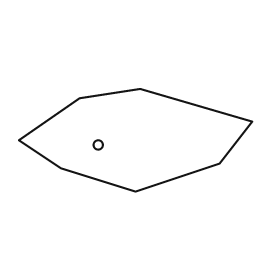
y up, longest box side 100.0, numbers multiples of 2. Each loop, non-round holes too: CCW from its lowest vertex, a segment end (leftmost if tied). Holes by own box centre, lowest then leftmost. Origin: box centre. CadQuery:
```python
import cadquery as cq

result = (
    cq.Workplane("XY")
    .moveTo(0.0, -22.0)
    .lineTo(36.0, -10.0)
    .lineTo(50.0, 8.0)
    .lineTo(2.0, 22.0)
    .lineTo(-24.0, 18.0)
    .lineTo(-50.0, 0.0)
    .lineTo(-32.0, -12.0)
    .close()
    .moveTo(-16.0, -2.0)
    .circle(2.0)
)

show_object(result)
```